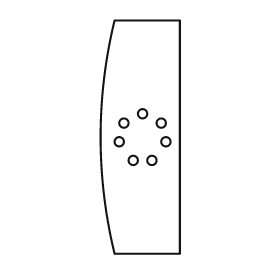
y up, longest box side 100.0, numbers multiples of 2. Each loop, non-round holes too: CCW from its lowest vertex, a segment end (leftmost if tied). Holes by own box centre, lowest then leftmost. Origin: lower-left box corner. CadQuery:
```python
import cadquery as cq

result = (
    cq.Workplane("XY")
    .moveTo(6.0, 0.0)
    .lineTo(34.0, 0.0)
    .lineTo(34.0, 100.0)
    .lineTo(6.0, 100.0)
    .threePointArc((0.0, 50.0), (6.0, 0.0))
    .close()
    .moveTo(14.0, 40.0)
    .circle(2.0)
    .moveTo(22.0, 40.0)
    .circle(2.0)
    .moveTo(8.0, 48.0)
    .circle(2.0)
    .moveTo(28.0, 48.0)
    .circle(2.0)
    .moveTo(10.0, 56.0)
    .circle(2.0)
    .moveTo(26.0, 56.0)
    .circle(2.0)
    .moveTo(18.0, 60.0)
    .circle(2.0)
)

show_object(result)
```